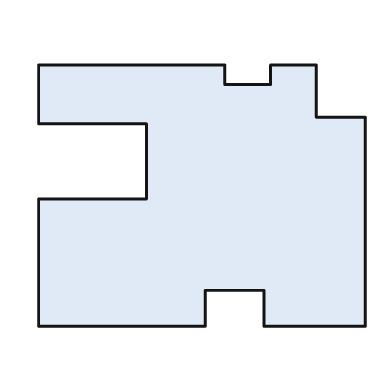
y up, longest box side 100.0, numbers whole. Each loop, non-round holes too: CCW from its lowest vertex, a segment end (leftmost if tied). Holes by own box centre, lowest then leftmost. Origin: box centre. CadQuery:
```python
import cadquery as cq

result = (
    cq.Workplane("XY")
    .moveTo(-50.0, -40.0)
    .lineTo(1.0, -40.0)
    .lineTo(1.0, -29.0)
    .lineTo(19.0, -29.0)
    .lineTo(19.0, -40.0)
    .lineTo(50.0, -40.0)
    .lineTo(50.0, 24.0)
    .lineTo(35.0, 24.0)
    .lineTo(35.0, 40.0)
    .lineTo(21.0, 40.0)
    .lineTo(21.0, 34.0)
    .lineTo(7.0, 34.0)
    .lineTo(7.0, 40.0)
    .lineTo(-50.0, 40.0)
    .lineTo(-50.0, 22.0)
    .lineTo(-17.0, 22.0)
    .lineTo(-17.0, -1.0)
    .lineTo(-50.0, -1.0)
    .close()
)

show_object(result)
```